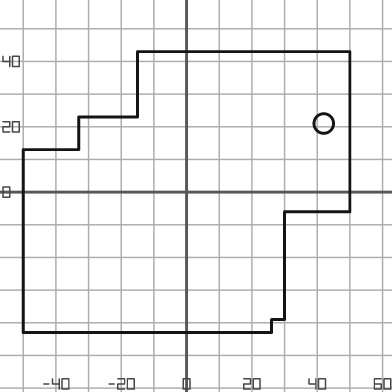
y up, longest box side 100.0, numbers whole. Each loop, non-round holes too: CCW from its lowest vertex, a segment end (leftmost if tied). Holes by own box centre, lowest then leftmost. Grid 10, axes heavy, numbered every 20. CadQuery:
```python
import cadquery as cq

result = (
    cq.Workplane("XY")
    .moveTo(-50.0, -43.0)
    .lineTo(26.0, -43.0)
    .lineTo(26.0, -39.0)
    .lineTo(30.0, -39.0)
    .lineTo(30.0, -6.0)
    .lineTo(50.0, -6.0)
    .lineTo(50.0, 43.0)
    .lineTo(-15.0, 43.0)
    .lineTo(-15.0, 23.0)
    .lineTo(-33.0, 23.0)
    .lineTo(-33.0, 13.0)
    .lineTo(-50.0, 13.0)
    .close()
    .moveTo(42.0, 21.0)
    .circle(3.0)
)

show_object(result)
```